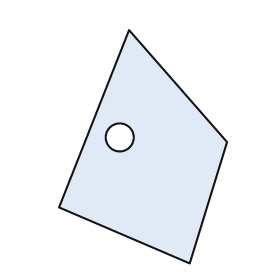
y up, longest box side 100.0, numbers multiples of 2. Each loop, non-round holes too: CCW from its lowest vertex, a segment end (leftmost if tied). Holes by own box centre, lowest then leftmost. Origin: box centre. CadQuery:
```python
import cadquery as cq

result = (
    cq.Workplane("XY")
    .moveTo(20.0, -50.0)
    .lineTo(36.0, 2.0)
    .lineTo(-6.0, 50.0)
    .lineTo(-36.0, -26.0)
    .close()
    .moveTo(-10.0, 4.0)
    .circle(6.0)
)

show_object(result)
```